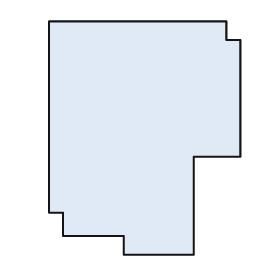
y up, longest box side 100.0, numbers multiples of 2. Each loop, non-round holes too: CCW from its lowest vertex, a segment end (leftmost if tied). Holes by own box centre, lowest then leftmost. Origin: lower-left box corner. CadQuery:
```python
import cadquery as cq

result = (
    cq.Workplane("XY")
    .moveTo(32.0, 0.0)
    .lineTo(62.0, 0.0)
    .lineTo(62.0, 42.0)
    .lineTo(82.0, 42.0)
    .lineTo(82.0, 92.0)
    .lineTo(76.0, 92.0)
    .lineTo(76.0, 100.0)
    .lineTo(0.0, 100.0)
    .lineTo(0.0, 18.0)
    .lineTo(6.0, 18.0)
    .lineTo(6.0, 8.0)
    .lineTo(32.0, 8.0)
    .close()
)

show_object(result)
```